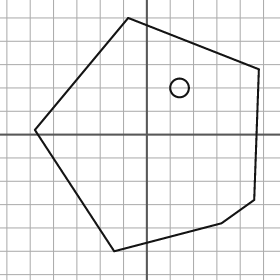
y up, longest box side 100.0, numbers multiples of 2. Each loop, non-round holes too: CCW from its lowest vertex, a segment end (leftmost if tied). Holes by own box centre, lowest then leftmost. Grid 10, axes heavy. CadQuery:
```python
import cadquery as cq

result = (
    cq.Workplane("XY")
    .moveTo(-14.0, -50.0)
    .lineTo(32.0, -38.0)
    .lineTo(46.0, -28.0)
    .lineTo(48.0, 28.0)
    .lineTo(-8.0, 50.0)
    .lineTo(-48.0, 2.0)
    .close()
    .moveTo(14.0, 20.0)
    .circle(4.0)
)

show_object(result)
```